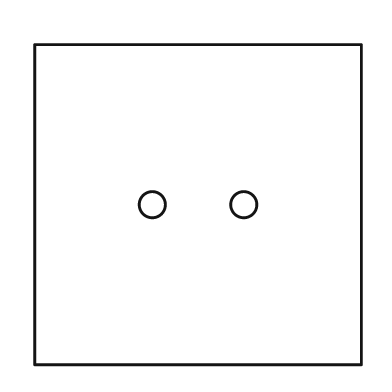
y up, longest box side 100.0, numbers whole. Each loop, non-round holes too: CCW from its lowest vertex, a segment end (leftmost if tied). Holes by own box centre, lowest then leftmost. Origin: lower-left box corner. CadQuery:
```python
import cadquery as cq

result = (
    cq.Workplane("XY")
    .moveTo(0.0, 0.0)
    .lineTo(100.0, 0.0)
    .lineTo(100.0, 98.0)
    .lineTo(0.0, 98.0)
    .close()
    .moveTo(36.0, 49.0)
    .circle(4.0)
    .moveTo(64.0, 49.0)
    .circle(4.0)
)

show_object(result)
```